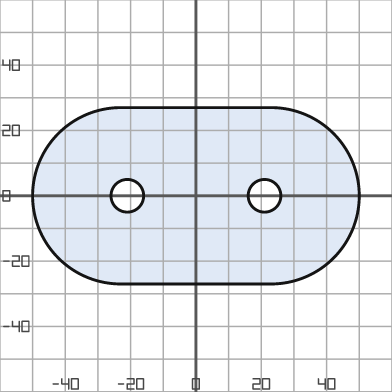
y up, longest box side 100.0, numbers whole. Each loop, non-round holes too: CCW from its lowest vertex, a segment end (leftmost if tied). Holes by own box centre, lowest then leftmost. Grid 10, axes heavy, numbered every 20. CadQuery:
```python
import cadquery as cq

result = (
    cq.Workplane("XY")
    .moveTo(-23.0, -27.0)
    .lineTo(23.0, -27.0)
    .threePointArc((50.0, 0.0), (23.0, 27.0))
    .lineTo(-23.0, 27.0)
    .threePointArc((-50.0, 0.0), (-23.0, -27.0))
    .close()
    .moveTo(-21.0, 0.0)
    .circle(5.0)
    .moveTo(21.0, 0.0)
    .circle(5.0)
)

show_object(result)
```